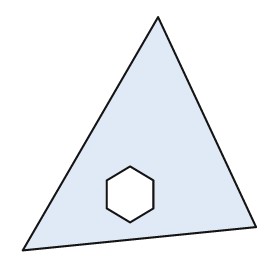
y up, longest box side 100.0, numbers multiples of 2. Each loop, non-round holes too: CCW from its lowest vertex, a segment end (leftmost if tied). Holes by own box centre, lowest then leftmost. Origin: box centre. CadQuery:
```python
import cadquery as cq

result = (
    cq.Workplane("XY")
    .moveTo(-50.0, -50.0)
    .lineTo(50.0, -40.0)
    .lineTo(8.0, 50.0)
    .close()
    .moveTo(-4.0, -38.0)
    .lineTo(6.0, -32.0)
    .lineTo(6.0, -20.0)
    .lineTo(-4.0, -14.0)
    .lineTo(-14.0, -20.0)
    .lineTo(-14.0, -32.0)
    .close()
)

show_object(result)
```